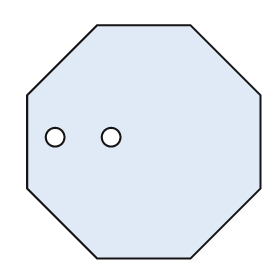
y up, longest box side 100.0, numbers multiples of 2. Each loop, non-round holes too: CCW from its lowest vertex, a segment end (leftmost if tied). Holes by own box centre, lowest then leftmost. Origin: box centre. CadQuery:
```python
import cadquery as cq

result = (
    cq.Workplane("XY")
    .moveTo(-20.0, -50.0)
    .lineTo(20.0, -50.0)
    .lineTo(50.0, -20.0)
    .lineTo(50.0, 20.0)
    .lineTo(20.0, 50.0)
    .lineTo(-20.0, 50.0)
    .lineTo(-50.0, 20.0)
    .lineTo(-50.0, -20.0)
    .close()
    .moveTo(-38.0, 2.0)
    .circle(4.0)
    .moveTo(-14.0, 2.0)
    .circle(4.0)
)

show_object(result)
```